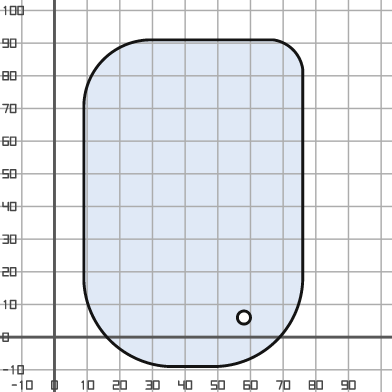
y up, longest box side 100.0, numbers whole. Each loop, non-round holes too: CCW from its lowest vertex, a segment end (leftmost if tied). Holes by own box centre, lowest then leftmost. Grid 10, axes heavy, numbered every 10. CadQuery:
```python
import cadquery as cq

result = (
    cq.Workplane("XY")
    .moveTo(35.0, -9.0)
    .lineTo(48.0, -9.0)
    .threePointArc((68.0, -1.0), (76.0, 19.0))
    .lineTo(76.0, 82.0)
    .threePointArc((73.0, 88.0), (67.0, 91.0))
    .lineTo(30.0, 91.0)
    .threePointArc((15.0, 85.0), (9.0, 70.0))
    .lineTo(9.0, 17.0)
    .threePointArc((17.0, -1.0), (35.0, -9.0))
    .close()
    .moveTo(58.0, 6.0)
    .circle(2.0)
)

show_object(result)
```